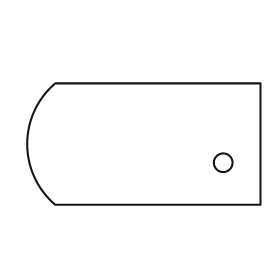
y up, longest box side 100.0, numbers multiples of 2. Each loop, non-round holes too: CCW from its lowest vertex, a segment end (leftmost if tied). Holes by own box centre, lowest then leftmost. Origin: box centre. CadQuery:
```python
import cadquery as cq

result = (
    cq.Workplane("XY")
    .moveTo(-38.0, -26.0)
    .lineTo(50.0, -26.0)
    .lineTo(50.0, 26.0)
    .lineTo(-38.0, 26.0)
    .threePointArc((-50.0, 0.0), (-38.0, -26.0))
    .close()
    .moveTo(34.0, -8.0)
    .circle(4.0)
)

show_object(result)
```